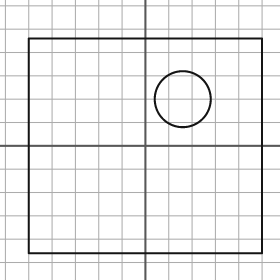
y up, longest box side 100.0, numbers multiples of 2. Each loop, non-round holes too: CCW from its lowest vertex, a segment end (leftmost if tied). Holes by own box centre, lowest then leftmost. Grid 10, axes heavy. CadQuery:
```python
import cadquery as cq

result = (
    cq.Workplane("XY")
    .moveTo(-50.0, -46.0)
    .lineTo(50.0, -46.0)
    .lineTo(50.0, 46.0)
    .lineTo(-50.0, 46.0)
    .close()
    .moveTo(16.0, 20.0)
    .circle(12.0)
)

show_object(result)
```